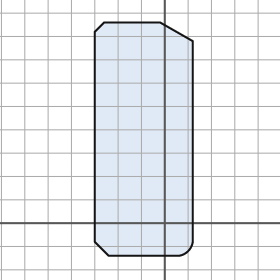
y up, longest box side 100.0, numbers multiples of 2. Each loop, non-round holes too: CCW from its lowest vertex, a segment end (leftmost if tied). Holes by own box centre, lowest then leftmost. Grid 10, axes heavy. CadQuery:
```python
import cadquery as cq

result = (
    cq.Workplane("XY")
    .moveTo(-24.0, -14.0)
    .lineTo(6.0, -14.0)
    .threePointArc((10.0, -12.0), (12.0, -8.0))
    .lineTo(12.0, 78.0)
    .lineTo(-2.0, 86.0)
    .lineTo(-26.0, 86.0)
    .lineTo(-30.0, 82.0)
    .lineTo(-30.0, -8.0)
    .close()
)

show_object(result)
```